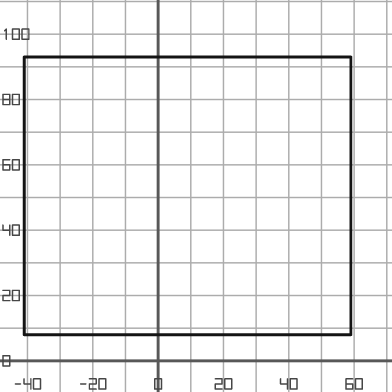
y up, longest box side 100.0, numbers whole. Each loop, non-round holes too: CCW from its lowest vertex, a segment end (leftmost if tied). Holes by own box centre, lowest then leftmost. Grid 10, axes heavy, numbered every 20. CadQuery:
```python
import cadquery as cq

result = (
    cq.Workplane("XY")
    .moveTo(-41.0, 8.0)
    .lineTo(59.0, 8.0)
    .lineTo(59.0, 93.0)
    .lineTo(-41.0, 93.0)
    .close()
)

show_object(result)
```